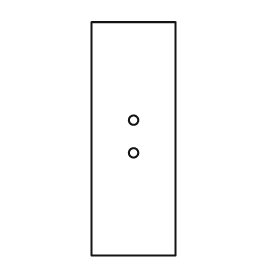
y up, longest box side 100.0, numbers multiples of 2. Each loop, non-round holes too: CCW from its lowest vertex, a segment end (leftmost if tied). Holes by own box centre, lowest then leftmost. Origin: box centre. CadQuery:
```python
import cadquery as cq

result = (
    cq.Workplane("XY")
    .moveTo(-18.0, -50.0)
    .lineTo(18.0, -50.0)
    .lineTo(18.0, 50.0)
    .lineTo(-18.0, 50.0)
    .close()
    .moveTo(0.0, -6.0)
    .circle(2.0)
    .moveTo(0.0, 8.0)
    .circle(2.0)
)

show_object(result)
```